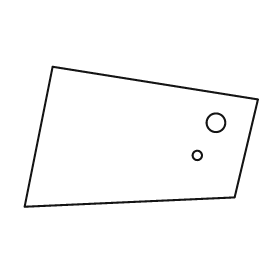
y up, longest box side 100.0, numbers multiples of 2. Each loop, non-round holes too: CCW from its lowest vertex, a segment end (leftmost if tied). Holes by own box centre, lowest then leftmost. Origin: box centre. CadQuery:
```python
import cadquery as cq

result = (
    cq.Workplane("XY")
    .moveTo(-50.0, -30.0)
    .lineTo(40.0, -26.0)
    .lineTo(50.0, 16.0)
    .lineTo(-38.0, 30.0)
    .close()
    .moveTo(24.0, -8.0)
    .circle(2.0)
    .moveTo(32.0, 6.0)
    .circle(4.0)
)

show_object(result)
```